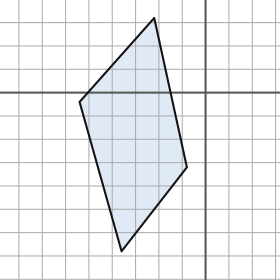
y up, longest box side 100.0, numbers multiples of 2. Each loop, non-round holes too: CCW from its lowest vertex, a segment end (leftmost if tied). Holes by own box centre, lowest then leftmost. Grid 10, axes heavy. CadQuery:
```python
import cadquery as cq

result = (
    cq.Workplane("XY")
    .moveTo(-36.0, -68.0)
    .lineTo(-8.0, -32.0)
    .lineTo(-22.0, 32.0)
    .lineTo(-54.0, -4.0)
    .close()
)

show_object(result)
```